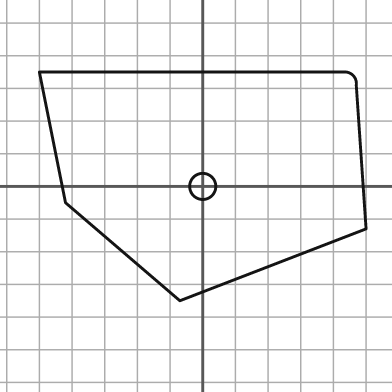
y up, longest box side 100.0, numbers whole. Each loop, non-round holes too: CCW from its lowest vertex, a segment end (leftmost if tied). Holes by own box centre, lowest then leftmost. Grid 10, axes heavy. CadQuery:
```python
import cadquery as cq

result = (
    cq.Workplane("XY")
    .moveTo(-7.0, -35.0)
    .lineTo(50.0, -13.0)
    .lineTo(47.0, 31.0)
    .threePointArc((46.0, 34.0), (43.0, 35.0))
    .lineTo(-50.0, 35.0)
    .lineTo(-42.0, -5.0)
    .close()
    .moveTo(0.0, 0.0)
    .circle(4.0)
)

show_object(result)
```